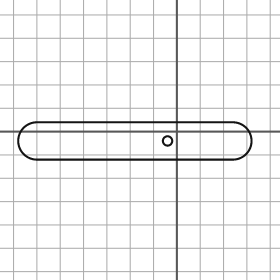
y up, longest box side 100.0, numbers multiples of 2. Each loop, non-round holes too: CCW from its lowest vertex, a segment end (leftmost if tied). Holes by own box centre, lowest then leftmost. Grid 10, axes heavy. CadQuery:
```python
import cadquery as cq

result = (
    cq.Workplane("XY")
    .moveTo(-60.0, -12.0)
    .lineTo(24.0, -12.0)
    .threePointArc((32.0, -4.0), (24.0, 4.0))
    .lineTo(-60.0, 4.0)
    .threePointArc((-68.0, -4.0), (-60.0, -12.0))
    .close()
    .moveTo(-4.0, -4.0)
    .circle(2.0)
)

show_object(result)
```